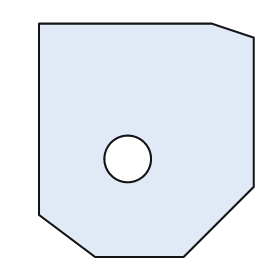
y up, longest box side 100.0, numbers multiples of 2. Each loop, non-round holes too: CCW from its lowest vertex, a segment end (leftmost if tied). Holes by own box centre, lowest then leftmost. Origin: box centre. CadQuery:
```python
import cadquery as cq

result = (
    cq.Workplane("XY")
    .moveTo(-22.0, -50.0)
    .lineTo(16.0, -50.0)
    .lineTo(46.0, -20.0)
    .lineTo(46.0, 44.0)
    .lineTo(28.0, 50.0)
    .lineTo(-46.0, 50.0)
    .lineTo(-46.0, -32.0)
    .close()
    .moveTo(-8.0, -8.0)
    .circle(10.0)
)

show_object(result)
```